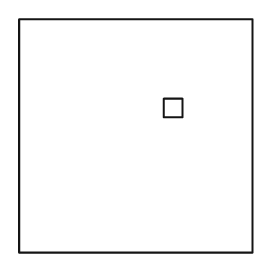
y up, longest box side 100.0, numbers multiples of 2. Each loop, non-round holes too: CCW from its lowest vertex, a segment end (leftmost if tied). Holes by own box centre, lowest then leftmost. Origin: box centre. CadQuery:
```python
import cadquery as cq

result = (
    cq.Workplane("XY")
    .moveTo(-50.0, -50.0)
    .lineTo(50.0, -50.0)
    .lineTo(50.0, 50.0)
    .lineTo(-50.0, 50.0)
    .close()
    .moveTo(12.0, 8.0)
    .lineTo(20.0, 8.0)
    .lineTo(20.0, 16.0)
    .lineTo(12.0, 16.0)
    .close()
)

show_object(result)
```